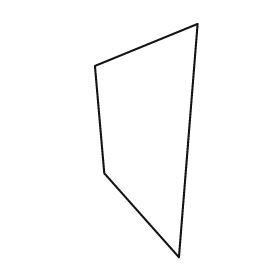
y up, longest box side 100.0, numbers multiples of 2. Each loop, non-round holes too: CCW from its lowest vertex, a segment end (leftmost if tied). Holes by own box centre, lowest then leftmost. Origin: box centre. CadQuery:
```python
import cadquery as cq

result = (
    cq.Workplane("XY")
    .moveTo(14.0, -50.0)
    .lineTo(22.0, 50.0)
    .lineTo(-22.0, 32.0)
    .lineTo(-18.0, -14.0)
    .close()
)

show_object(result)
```